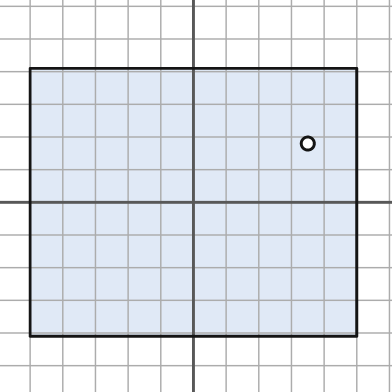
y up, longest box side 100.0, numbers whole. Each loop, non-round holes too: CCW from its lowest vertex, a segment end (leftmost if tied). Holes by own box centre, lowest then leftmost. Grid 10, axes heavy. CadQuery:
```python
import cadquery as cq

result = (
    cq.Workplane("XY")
    .moveTo(-50.0, -41.0)
    .lineTo(50.0, -41.0)
    .lineTo(50.0, 41.0)
    .lineTo(-50.0, 41.0)
    .close()
    .moveTo(35.0, 18.0)
    .circle(2.0)
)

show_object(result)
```